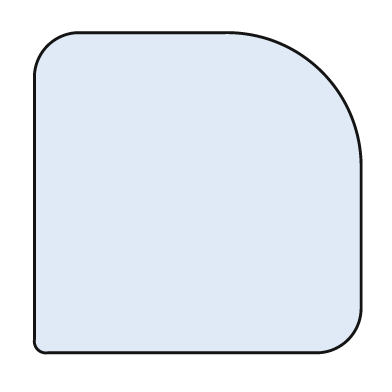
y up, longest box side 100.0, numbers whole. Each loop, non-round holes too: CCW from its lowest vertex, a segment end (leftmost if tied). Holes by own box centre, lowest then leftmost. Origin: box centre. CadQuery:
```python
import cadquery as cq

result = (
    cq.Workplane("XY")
    .moveTo(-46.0, -49.0)
    .lineTo(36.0, -49.0)
    .threePointArc((46.0, -45.0), (50.0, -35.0))
    .lineTo(50.0, 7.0)
    .threePointArc((38.0, 37.0), (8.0, 49.0))
    .lineTo(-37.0, 49.0)
    .threePointArc((-46.0, 45.0), (-50.0, 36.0))
    .lineTo(-50.0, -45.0)
    .threePointArc((-49.0, -48.0), (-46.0, -49.0))
    .close()
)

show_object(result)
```